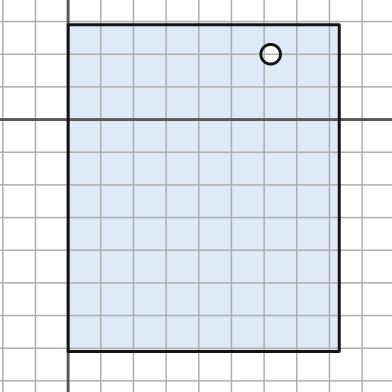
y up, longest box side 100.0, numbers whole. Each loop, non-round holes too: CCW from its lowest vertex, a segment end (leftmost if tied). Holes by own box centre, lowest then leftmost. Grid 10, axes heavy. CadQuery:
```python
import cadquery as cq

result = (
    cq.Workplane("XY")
    .moveTo(0.0, -71.0)
    .lineTo(83.0, -71.0)
    .lineTo(83.0, 29.0)
    .lineTo(0.0, 29.0)
    .close()
    .moveTo(62.0, 20.0)
    .circle(3.0)
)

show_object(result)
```